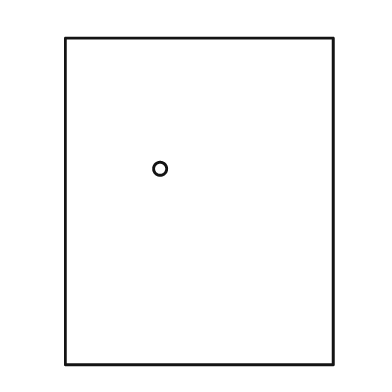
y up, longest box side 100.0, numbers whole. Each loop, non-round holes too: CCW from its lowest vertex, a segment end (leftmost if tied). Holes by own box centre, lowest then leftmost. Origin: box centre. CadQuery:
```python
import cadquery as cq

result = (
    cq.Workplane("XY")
    .moveTo(-41.0, -50.0)
    .lineTo(41.0, -50.0)
    .lineTo(41.0, 50.0)
    .lineTo(-41.0, 50.0)
    .close()
    .moveTo(-12.0, 10.0)
    .circle(2.0)
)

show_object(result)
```